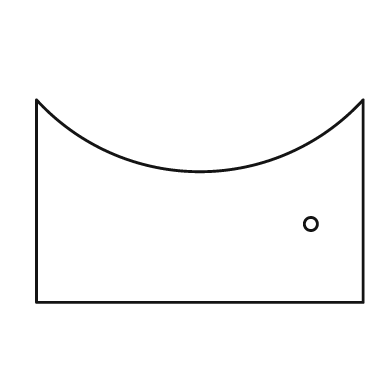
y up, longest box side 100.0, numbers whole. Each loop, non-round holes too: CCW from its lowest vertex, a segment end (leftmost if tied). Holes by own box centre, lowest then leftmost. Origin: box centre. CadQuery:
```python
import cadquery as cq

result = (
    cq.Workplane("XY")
    .moveTo(-50.0, -31.0)
    .lineTo(50.0, -31.0)
    .lineTo(50.0, 31.0)
    .threePointArc((0.0, 9.0), (-50.0, 31.0))
    .close()
    .moveTo(34.0, -7.0)
    .circle(2.0)
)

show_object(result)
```